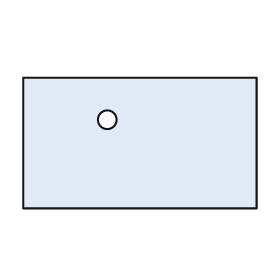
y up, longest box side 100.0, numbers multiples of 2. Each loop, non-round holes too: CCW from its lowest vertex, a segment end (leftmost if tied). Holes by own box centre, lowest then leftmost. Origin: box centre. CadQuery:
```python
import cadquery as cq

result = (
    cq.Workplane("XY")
    .moveTo(-50.0, -28.0)
    .lineTo(50.0, -28.0)
    .lineTo(50.0, 28.0)
    .lineTo(-50.0, 28.0)
    .close()
    .moveTo(-14.0, 10.0)
    .circle(4.0)
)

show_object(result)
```